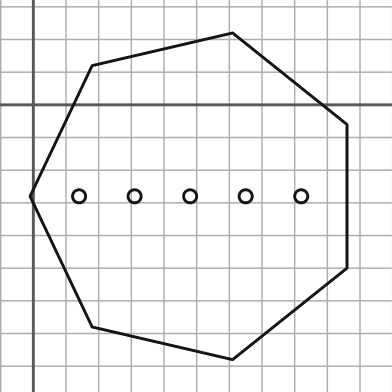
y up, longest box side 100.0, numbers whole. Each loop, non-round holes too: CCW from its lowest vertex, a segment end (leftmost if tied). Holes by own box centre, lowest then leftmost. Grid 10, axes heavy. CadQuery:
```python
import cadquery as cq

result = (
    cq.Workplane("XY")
    .moveTo(61.0, -78.0)
    .lineTo(96.0, -50.0)
    .lineTo(96.0, -6.0)
    .lineTo(61.0, 22.0)
    .lineTo(18.0, 12.0)
    .lineTo(-1.0, -28.0)
    .lineTo(18.0, -68.0)
    .close()
    .moveTo(14.0, -28.0)
    .circle(2.0)
    .moveTo(31.0, -28.0)
    .circle(2.0)
    .moveTo(48.0, -28.0)
    .circle(2.0)
    .moveTo(65.0, -28.0)
    .circle(2.0)
    .moveTo(82.0, -28.0)
    .circle(2.0)
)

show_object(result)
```